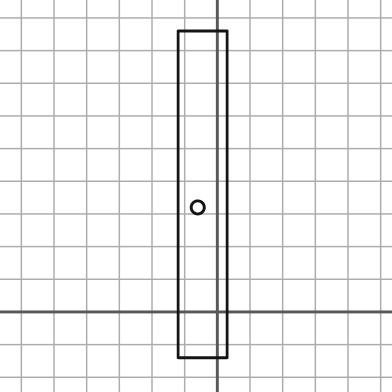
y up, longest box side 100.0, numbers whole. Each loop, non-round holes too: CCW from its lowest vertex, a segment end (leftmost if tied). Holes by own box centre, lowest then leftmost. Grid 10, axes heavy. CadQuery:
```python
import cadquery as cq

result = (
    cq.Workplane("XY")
    .moveTo(-12.0, -14.0)
    .lineTo(3.0, -14.0)
    .lineTo(3.0, 86.0)
    .lineTo(-12.0, 86.0)
    .close()
    .moveTo(-6.0, 32.0)
    .circle(2.0)
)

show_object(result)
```